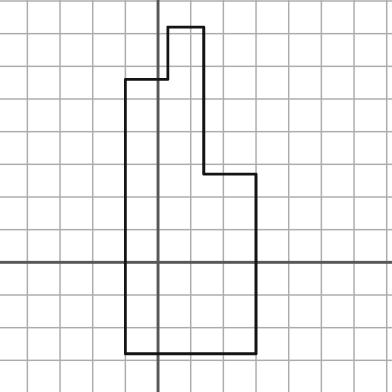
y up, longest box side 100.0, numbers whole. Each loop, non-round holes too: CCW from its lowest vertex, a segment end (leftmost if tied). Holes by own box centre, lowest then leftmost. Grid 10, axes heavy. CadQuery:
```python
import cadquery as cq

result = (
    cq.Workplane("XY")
    .moveTo(-10.0, -28.0)
    .lineTo(30.0, -28.0)
    .lineTo(30.0, 27.0)
    .lineTo(14.0, 27.0)
    .lineTo(14.0, 72.0)
    .lineTo(3.0, 72.0)
    .lineTo(3.0, 56.0)
    .lineTo(-10.0, 56.0)
    .close()
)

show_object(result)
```